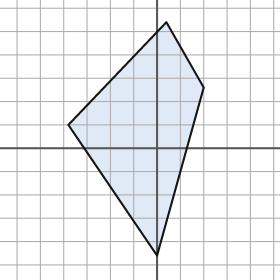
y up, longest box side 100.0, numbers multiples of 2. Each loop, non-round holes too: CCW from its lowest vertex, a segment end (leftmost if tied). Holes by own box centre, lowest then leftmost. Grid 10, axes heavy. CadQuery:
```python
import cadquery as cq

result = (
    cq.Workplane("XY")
    .moveTo(0.0, -46.0)
    .lineTo(20.0, 26.0)
    .lineTo(4.0, 54.0)
    .lineTo(-38.0, 10.0)
    .close()
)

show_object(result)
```